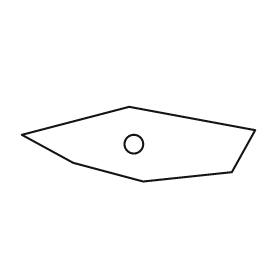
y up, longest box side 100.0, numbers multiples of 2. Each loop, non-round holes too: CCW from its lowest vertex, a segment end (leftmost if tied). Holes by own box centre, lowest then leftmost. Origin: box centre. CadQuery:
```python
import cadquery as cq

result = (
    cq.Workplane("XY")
    .moveTo(2.0, -16.0)
    .lineTo(40.0, -12.0)
    .lineTo(50.0, 6.0)
    .lineTo(-4.0, 16.0)
    .lineTo(-50.0, 4.0)
    .lineTo(-28.0, -8.0)
    .close()
    .moveTo(-2.0, 0.0)
    .circle(4.0)
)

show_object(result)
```